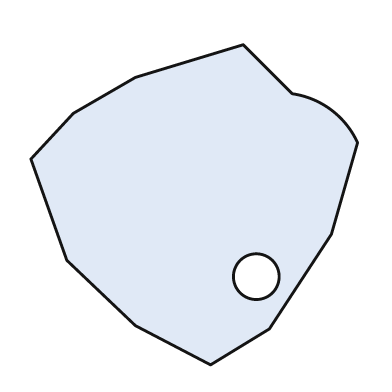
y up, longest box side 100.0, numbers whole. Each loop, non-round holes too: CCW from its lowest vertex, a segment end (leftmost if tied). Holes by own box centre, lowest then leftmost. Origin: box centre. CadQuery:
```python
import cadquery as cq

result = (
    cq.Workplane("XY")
    .moveTo(5.0, -49.0)
    .lineTo(23.0, -38.0)
    .lineTo(42.0, -9.0)
    .lineTo(50.0, 19.0)
    .threePointArc((42.0, 29.0), (30.0, 34.0))
    .lineTo(15.0, 49.0)
    .lineTo(-18.0, 39.0)
    .lineTo(-37.0, 28.0)
    .lineTo(-50.0, 14.0)
    .lineTo(-39.0, -17.0)
    .lineTo(-18.0, -37.0)
    .close()
    .moveTo(19.0, -22.0)
    .circle(7.0)
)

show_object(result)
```